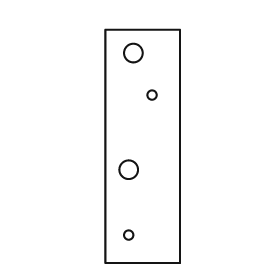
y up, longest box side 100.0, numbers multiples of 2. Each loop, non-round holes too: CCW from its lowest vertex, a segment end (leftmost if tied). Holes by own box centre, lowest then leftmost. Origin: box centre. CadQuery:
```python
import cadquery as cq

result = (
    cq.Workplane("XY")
    .moveTo(-16.0, -50.0)
    .lineTo(16.0, -50.0)
    .lineTo(16.0, 50.0)
    .lineTo(-16.0, 50.0)
    .close()
    .moveTo(-6.0, -38.0)
    .circle(2.0)
    .moveTo(-6.0, -10.0)
    .circle(4.0)
    .moveTo(4.0, 22.0)
    .circle(2.0)
    .moveTo(-4.0, 40.0)
    .circle(4.0)
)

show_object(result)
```